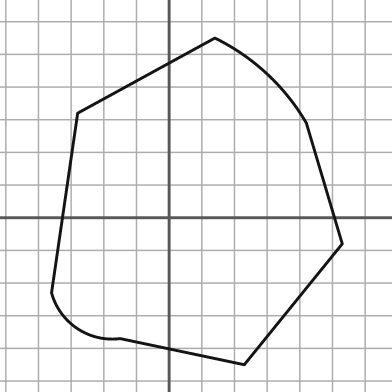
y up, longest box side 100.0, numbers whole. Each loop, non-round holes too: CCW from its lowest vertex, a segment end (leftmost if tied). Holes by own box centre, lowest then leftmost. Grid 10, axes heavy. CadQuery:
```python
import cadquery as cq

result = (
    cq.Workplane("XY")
    .moveTo(23.0, -45.0)
    .lineTo(53.0, -8.0)
    .lineTo(42.0, 29.0)
    .threePointArc((30.0, 44.0), (14.0, 55.0))
    .lineTo(-28.0, 32.0)
    .lineTo(-36.0, -23.0)
    .threePointArc((-28.0, -34.0), (-15.0, -37.0))
    .close()
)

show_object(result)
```